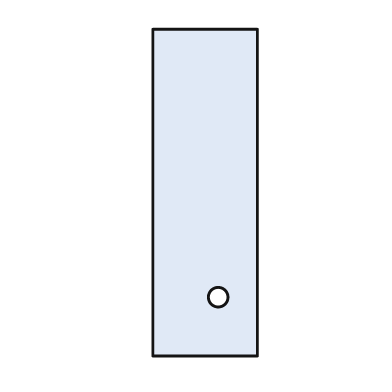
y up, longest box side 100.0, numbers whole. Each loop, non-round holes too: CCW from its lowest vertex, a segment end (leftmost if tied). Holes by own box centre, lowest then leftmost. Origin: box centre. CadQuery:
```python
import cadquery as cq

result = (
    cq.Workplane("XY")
    .moveTo(-16.0, -50.0)
    .lineTo(16.0, -50.0)
    .lineTo(16.0, 50.0)
    .lineTo(-16.0, 50.0)
    .close()
    .moveTo(4.0, -32.0)
    .circle(3.0)
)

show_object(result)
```